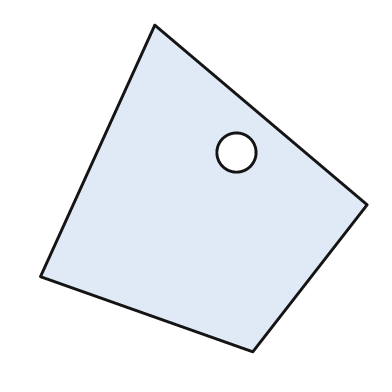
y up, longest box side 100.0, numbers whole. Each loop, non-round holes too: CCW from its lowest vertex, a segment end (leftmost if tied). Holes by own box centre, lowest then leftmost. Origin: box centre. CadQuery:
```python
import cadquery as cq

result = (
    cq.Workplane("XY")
    .moveTo(15.0, -50.0)
    .lineTo(50.0, -5.0)
    .lineTo(-15.0, 50.0)
    .lineTo(-50.0, -27.0)
    .close()
    .moveTo(10.0, 11.0)
    .circle(6.0)
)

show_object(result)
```